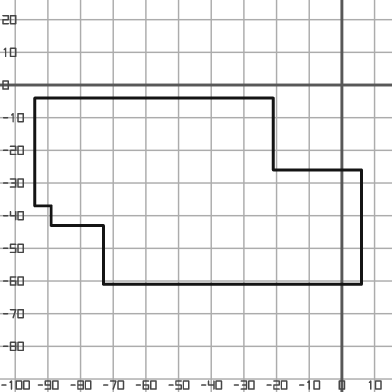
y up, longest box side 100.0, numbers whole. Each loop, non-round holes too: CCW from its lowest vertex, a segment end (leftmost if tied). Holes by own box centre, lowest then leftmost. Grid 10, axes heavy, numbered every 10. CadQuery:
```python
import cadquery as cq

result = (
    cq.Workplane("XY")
    .moveTo(-73.0, -61.0)
    .lineTo(6.0, -61.0)
    .lineTo(6.0, -26.0)
    .lineTo(-21.0, -26.0)
    .lineTo(-21.0, -4.0)
    .lineTo(-94.0, -4.0)
    .lineTo(-94.0, -37.0)
    .lineTo(-89.0, -37.0)
    .lineTo(-89.0, -43.0)
    .lineTo(-73.0, -43.0)
    .close()
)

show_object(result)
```